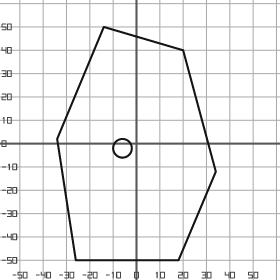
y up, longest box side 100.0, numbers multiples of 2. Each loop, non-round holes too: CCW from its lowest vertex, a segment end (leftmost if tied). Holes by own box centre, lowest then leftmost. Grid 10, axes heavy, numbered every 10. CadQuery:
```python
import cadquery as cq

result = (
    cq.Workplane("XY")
    .moveTo(-26.0, -50.0)
    .lineTo(18.0, -50.0)
    .lineTo(34.0, -12.0)
    .lineTo(20.0, 40.0)
    .lineTo(-14.0, 50.0)
    .lineTo(-34.0, 2.0)
    .close()
    .moveTo(-6.0, -2.0)
    .circle(4.0)
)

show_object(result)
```